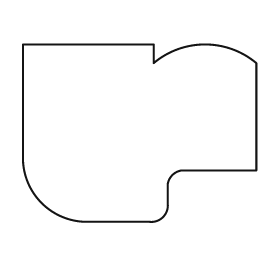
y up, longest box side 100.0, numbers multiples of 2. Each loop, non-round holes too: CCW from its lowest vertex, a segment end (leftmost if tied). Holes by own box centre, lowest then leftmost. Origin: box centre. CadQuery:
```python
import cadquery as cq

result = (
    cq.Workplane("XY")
    .moveTo(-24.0, -38.0)
    .lineTo(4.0, -38.0)
    .threePointArc((10.0, -36.0), (12.0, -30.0))
    .lineTo(12.0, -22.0)
    .threePointArc((14.0, -18.0), (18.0, -16.0))
    .lineTo(50.0, -16.0)
    .lineTo(50.0, 30.0)
    .threePointArc((28.0, 38.0), (6.0, 30.0))
    .lineTo(6.0, 38.0)
    .lineTo(-50.0, 38.0)
    .lineTo(-50.0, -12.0)
    .threePointArc((-42.0, -30.0), (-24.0, -38.0))
    .close()
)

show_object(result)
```